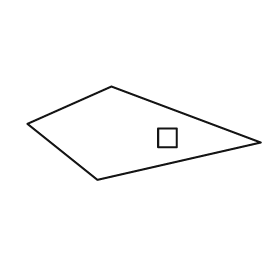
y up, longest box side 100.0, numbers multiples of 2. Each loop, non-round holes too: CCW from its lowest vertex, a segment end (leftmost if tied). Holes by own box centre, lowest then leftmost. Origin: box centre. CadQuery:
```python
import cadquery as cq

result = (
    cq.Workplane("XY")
    .moveTo(-20.0, -20.0)
    .lineTo(50.0, -4.0)
    .lineTo(-14.0, 20.0)
    .lineTo(-50.0, 4.0)
    .close()
    .moveTo(6.0, -6.0)
    .lineTo(14.0, -6.0)
    .lineTo(14.0, 2.0)
    .lineTo(6.0, 2.0)
    .close()
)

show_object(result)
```